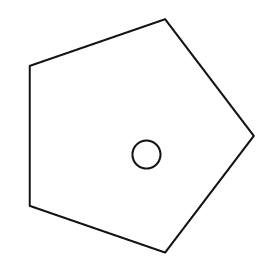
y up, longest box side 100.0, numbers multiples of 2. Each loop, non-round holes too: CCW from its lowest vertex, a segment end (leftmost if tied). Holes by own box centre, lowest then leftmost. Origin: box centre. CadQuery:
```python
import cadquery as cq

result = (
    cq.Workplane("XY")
    .moveTo(10.0, -50.0)
    .lineTo(48.0, 0.0)
    .lineTo(10.0, 50.0)
    .lineTo(-48.0, 30.0)
    .lineTo(-48.0, -30.0)
    .close()
    .moveTo(2.0, -8.0)
    .circle(6.0)
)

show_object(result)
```